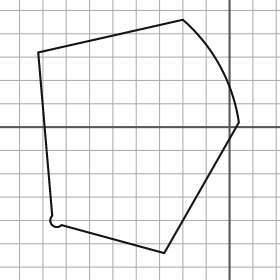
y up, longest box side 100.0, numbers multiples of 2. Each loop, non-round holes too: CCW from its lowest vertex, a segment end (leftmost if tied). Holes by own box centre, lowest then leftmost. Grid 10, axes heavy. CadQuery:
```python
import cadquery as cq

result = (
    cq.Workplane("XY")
    .moveTo(-28.0, -54.0)
    .lineTo(4.0, 2.0)
    .threePointArc((-4.0, 26.0), (-20.0, 46.0))
    .lineTo(-82.0, 32.0)
    .lineTo(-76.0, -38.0)
    .threePointArc((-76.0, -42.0), (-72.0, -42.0))
    .close()
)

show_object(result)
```